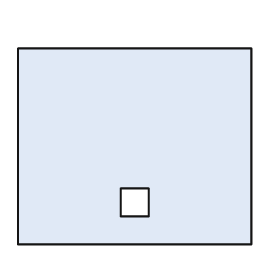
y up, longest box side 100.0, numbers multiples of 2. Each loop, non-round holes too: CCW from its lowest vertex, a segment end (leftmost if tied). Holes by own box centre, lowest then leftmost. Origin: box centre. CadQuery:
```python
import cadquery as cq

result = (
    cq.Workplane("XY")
    .moveTo(-50.0, -42.0)
    .lineTo(50.0, -42.0)
    .lineTo(50.0, 42.0)
    .lineTo(-50.0, 42.0)
    .close()
    .moveTo(-6.0, -30.0)
    .lineTo(6.0, -30.0)
    .lineTo(6.0, -18.0)
    .lineTo(-6.0, -18.0)
    .close()
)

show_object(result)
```